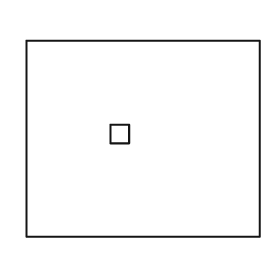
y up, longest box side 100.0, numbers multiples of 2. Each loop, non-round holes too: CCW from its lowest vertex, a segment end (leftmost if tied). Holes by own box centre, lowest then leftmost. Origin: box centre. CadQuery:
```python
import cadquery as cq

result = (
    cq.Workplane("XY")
    .moveTo(-50.0, -42.0)
    .lineTo(50.0, -42.0)
    .lineTo(50.0, 42.0)
    .lineTo(-50.0, 42.0)
    .close()
    .moveTo(-14.0, -2.0)
    .lineTo(-6.0, -2.0)
    .lineTo(-6.0, 6.0)
    .lineTo(-14.0, 6.0)
    .close()
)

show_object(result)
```